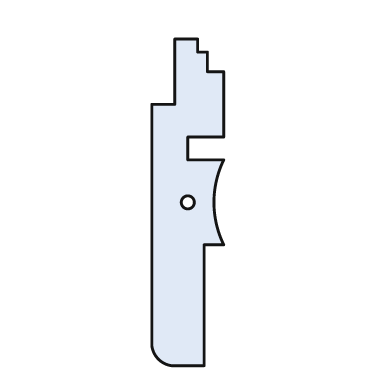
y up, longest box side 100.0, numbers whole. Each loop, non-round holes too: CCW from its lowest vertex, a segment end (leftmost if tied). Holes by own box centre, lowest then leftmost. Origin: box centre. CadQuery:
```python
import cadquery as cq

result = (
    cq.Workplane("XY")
    .moveTo(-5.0, -50.0)
    .lineTo(5.0, -50.0)
    .lineTo(5.0, -13.0)
    .lineTo(11.0, -13.0)
    .threePointArc((8.0, 0.0), (11.0, 13.0))
    .lineTo(0.0, 13.0)
    .lineTo(0.0, 20.0)
    .lineTo(11.0, 20.0)
    .lineTo(11.0, 40.0)
    .lineTo(6.0, 40.0)
    .lineTo(6.0, 46.0)
    .lineTo(3.0, 46.0)
    .lineTo(3.0, 50.0)
    .lineTo(-4.0, 50.0)
    .lineTo(-4.0, 30.0)
    .lineTo(-11.0, 30.0)
    .lineTo(-11.0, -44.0)
    .threePointArc((-9.0, -48.0), (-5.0, -50.0))
    .close()
    .moveTo(0.0, 0.0)
    .circle(2.0)
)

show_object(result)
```